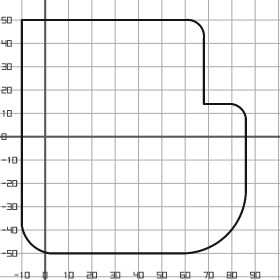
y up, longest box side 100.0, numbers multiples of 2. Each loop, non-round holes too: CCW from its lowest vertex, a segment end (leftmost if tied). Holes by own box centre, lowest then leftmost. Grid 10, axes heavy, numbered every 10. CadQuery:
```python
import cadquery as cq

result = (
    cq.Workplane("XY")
    .moveTo(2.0, -50.0)
    .lineTo(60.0, -50.0)
    .threePointArc((78.0, -42.0), (86.0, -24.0))
    .lineTo(86.0, 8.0)
    .threePointArc((84.0, 12.0), (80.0, 14.0))
    .lineTo(68.0, 14.0)
    .lineTo(68.0, 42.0)
    .threePointArc((66.0, 48.0), (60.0, 50.0))
    .lineTo(-10.0, 50.0)
    .lineTo(-10.0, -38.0)
    .threePointArc((-6.0, -46.0), (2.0, -50.0))
    .close()
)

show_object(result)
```